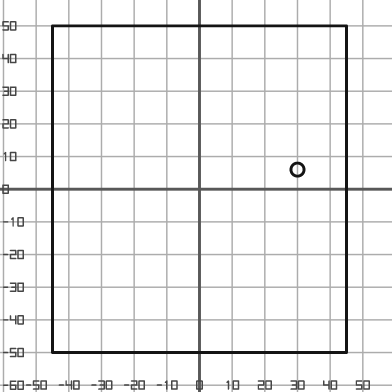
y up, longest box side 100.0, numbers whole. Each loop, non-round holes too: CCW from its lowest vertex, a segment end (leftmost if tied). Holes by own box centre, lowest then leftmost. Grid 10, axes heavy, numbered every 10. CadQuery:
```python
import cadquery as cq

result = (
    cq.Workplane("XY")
    .moveTo(-45.0, -50.0)
    .lineTo(45.0, -50.0)
    .lineTo(45.0, 50.0)
    .lineTo(-45.0, 50.0)
    .close()
    .moveTo(30.0, 6.0)
    .circle(2.0)
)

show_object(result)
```